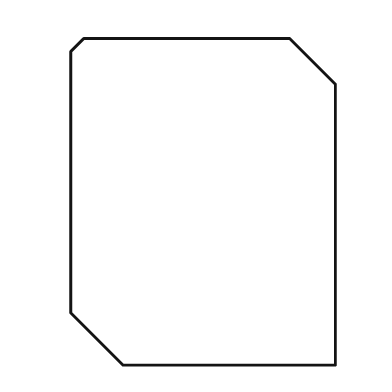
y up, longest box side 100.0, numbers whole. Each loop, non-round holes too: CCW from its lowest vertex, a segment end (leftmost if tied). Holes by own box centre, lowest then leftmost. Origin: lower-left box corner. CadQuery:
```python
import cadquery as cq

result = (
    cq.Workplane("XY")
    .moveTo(16.0, 0.0)
    .lineTo(81.0, 0.0)
    .lineTo(81.0, 86.0)
    .lineTo(67.0, 100.0)
    .lineTo(4.0, 100.0)
    .lineTo(0.0, 96.0)
    .lineTo(0.0, 16.0)
    .close()
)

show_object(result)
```